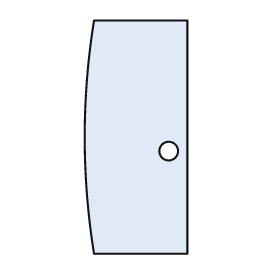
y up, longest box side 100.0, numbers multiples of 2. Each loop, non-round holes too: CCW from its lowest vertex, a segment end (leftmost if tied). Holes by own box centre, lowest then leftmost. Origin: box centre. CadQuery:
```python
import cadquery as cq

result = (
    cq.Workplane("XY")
    .moveTo(-18.0, -50.0)
    .lineTo(22.0, -50.0)
    .lineTo(22.0, 50.0)
    .lineTo(-18.0, 50.0)
    .threePointArc((-22.0, 0.0), (-18.0, -50.0))
    .close()
    .moveTo(14.0, -6.0)
    .circle(4.0)
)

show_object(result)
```